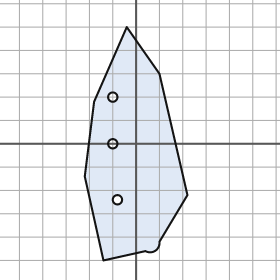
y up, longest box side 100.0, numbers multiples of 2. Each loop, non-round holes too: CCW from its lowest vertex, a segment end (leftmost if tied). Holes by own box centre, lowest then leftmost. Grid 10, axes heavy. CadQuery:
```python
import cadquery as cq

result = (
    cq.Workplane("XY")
    .moveTo(-14.0, -50.0)
    .lineTo(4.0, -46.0)
    .threePointArc((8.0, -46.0), (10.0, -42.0))
    .lineTo(22.0, -22.0)
    .lineTo(10.0, 30.0)
    .lineTo(-4.0, 50.0)
    .lineTo(-18.0, 18.0)
    .lineTo(-22.0, -14.0)
    .close()
    .moveTo(-8.0, -24.0)
    .circle(2.0)
    .moveTo(-10.0, 0.0)
    .circle(2.0)
    .moveTo(-10.0, 20.0)
    .circle(2.0)
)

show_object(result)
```